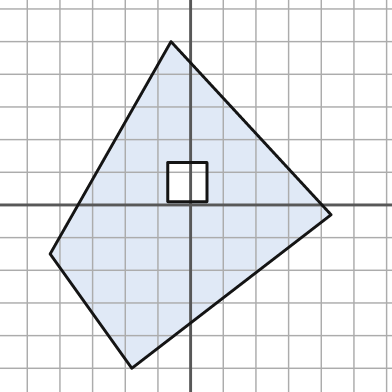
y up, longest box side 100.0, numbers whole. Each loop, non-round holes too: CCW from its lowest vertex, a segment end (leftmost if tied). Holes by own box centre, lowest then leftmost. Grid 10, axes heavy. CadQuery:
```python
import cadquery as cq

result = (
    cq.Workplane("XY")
    .moveTo(-18.0, -50.0)
    .lineTo(43.0, -3.0)
    .lineTo(-6.0, 50.0)
    .lineTo(-43.0, -15.0)
    .close()
    .moveTo(-7.0, 1.0)
    .lineTo(5.0, 1.0)
    .lineTo(5.0, 13.0)
    .lineTo(-7.0, 13.0)
    .close()
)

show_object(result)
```